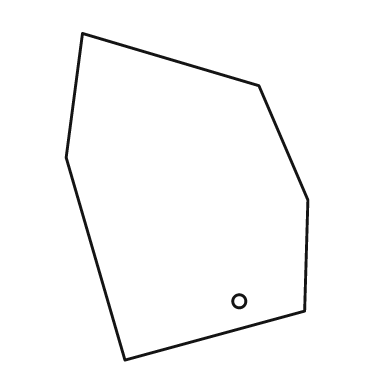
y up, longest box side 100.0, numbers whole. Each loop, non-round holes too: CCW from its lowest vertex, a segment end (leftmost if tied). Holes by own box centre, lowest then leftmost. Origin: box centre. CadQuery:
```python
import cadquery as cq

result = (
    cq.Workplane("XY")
    .moveTo(-19.0, -50.0)
    .lineTo(36.0, -35.0)
    .lineTo(37.0, -1.0)
    .lineTo(22.0, 34.0)
    .lineTo(-32.0, 50.0)
    .lineTo(-37.0, 12.0)
    .close()
    .moveTo(16.0, -32.0)
    .circle(2.0)
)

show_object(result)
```